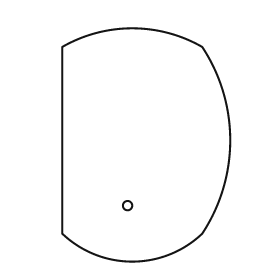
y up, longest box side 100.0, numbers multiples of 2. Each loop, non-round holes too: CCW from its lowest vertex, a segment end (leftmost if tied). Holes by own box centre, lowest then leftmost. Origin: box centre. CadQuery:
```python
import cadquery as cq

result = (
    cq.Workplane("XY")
    .moveTo(-36.0, -38.0)
    .threePointArc((-6.0, -50.0), (24.0, -38.0))
    .threePointArc((36.0, 2.0), (24.0, 42.0))
    .threePointArc((-6.0, 50.0), (-36.0, 42.0))
    .close()
    .moveTo(-8.0, -26.0)
    .circle(2.0)
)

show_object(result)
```